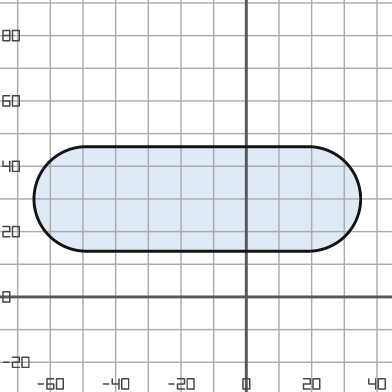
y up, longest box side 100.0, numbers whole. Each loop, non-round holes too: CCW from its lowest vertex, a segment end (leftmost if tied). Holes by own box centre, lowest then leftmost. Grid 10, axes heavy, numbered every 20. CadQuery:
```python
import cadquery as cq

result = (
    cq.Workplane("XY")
    .moveTo(-49.0, 14.0)
    .lineTo(19.0, 14.0)
    .threePointArc((35.0, 30.0), (19.0, 46.0))
    .lineTo(-49.0, 46.0)
    .threePointArc((-65.0, 30.0), (-49.0, 14.0))
    .close()
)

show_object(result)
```